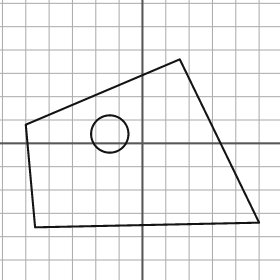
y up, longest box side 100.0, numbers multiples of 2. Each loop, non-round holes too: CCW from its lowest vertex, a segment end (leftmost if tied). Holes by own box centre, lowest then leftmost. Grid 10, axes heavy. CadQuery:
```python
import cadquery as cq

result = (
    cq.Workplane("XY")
    .moveTo(-46.0, -36.0)
    .lineTo(50.0, -34.0)
    .lineTo(16.0, 36.0)
    .lineTo(-50.0, 8.0)
    .close()
    .moveTo(-14.0, 4.0)
    .circle(8.0)
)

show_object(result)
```